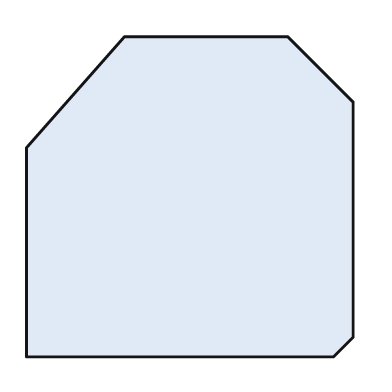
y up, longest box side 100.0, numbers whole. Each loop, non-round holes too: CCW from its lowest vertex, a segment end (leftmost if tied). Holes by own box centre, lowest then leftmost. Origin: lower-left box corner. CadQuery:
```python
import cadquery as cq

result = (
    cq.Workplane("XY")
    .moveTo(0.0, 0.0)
    .lineTo(94.0, 0.0)
    .lineTo(100.0, 6.0)
    .lineTo(100.0, 78.0)
    .lineTo(80.0, 98.0)
    .lineTo(30.0, 98.0)
    .lineTo(0.0, 64.0)
    .close()
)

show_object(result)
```